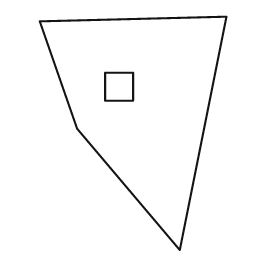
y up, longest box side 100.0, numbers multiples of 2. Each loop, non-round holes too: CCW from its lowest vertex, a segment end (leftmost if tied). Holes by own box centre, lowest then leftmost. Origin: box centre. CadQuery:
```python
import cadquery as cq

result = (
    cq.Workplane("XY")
    .moveTo(20.0, -50.0)
    .lineTo(40.0, 50.0)
    .lineTo(-40.0, 48.0)
    .lineTo(-24.0, 2.0)
    .close()
    .moveTo(-12.0, 14.0)
    .lineTo(0.0, 14.0)
    .lineTo(0.0, 26.0)
    .lineTo(-12.0, 26.0)
    .close()
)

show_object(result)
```